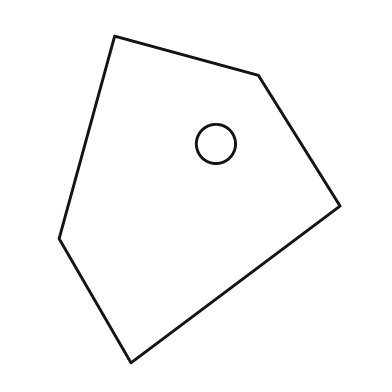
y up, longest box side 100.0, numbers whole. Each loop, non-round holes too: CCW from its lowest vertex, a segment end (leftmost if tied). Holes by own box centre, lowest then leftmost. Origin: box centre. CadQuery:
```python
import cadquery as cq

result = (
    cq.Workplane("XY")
    .moveTo(-21.0, -50.0)
    .lineTo(43.0, -2.0)
    .lineTo(18.0, 38.0)
    .lineTo(-26.0, 50.0)
    .lineTo(-43.0, -12.0)
    .close()
    .moveTo(5.0, 17.0)
    .circle(6.0)
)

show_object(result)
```